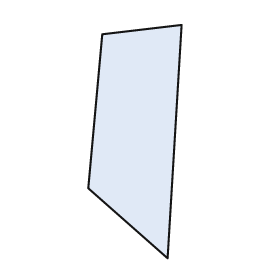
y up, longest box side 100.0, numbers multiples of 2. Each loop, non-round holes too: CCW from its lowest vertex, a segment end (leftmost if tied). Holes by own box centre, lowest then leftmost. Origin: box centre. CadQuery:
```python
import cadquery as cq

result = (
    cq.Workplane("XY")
    .moveTo(14.0, -50.0)
    .lineTo(20.0, 50.0)
    .lineTo(-14.0, 46.0)
    .lineTo(-20.0, -20.0)
    .close()
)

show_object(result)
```